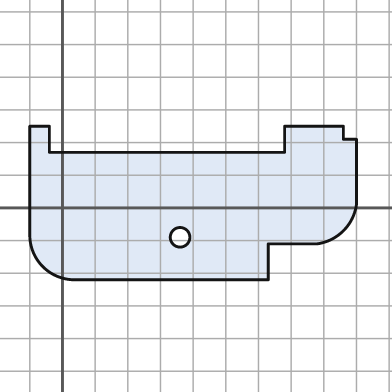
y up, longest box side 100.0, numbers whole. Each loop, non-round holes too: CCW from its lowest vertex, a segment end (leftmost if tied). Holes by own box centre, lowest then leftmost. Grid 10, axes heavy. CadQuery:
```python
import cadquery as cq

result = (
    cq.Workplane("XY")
    .moveTo(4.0, -22.0)
    .lineTo(63.0, -22.0)
    .lineTo(63.0, -11.0)
    .lineTo(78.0, -11.0)
    .threePointArc((86.0, -7.0), (90.0, 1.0))
    .lineTo(90.0, 21.0)
    .lineTo(86.0, 21.0)
    .lineTo(86.0, 25.0)
    .lineTo(68.0, 25.0)
    .lineTo(68.0, 17.0)
    .lineTo(-4.0, 17.0)
    .lineTo(-4.0, 25.0)
    .lineTo(-10.0, 25.0)
    .lineTo(-10.0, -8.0)
    .threePointArc((-6.0, -18.0), (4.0, -22.0))
    .close()
    .moveTo(36.0, -9.0)
    .circle(3.0)
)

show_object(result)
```